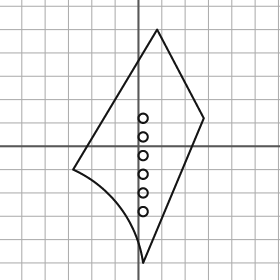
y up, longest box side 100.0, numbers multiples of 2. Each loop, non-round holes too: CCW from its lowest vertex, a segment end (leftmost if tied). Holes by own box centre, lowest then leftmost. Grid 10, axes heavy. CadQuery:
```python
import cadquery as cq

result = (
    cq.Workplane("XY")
    .moveTo(2.0, -50.0)
    .lineTo(28.0, 12.0)
    .lineTo(8.0, 50.0)
    .lineTo(-28.0, -10.0)
    .threePointArc((-8.0, -26.0), (2.0, -50.0))
    .close()
    .moveTo(2.0, -28.0)
    .circle(2.0)
    .moveTo(2.0, -20.0)
    .circle(2.0)
    .moveTo(2.0, -12.0)
    .circle(2.0)
    .moveTo(2.0, -4.0)
    .circle(2.0)
    .moveTo(2.0, 4.0)
    .circle(2.0)
    .moveTo(2.0, 12.0)
    .circle(2.0)
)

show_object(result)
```